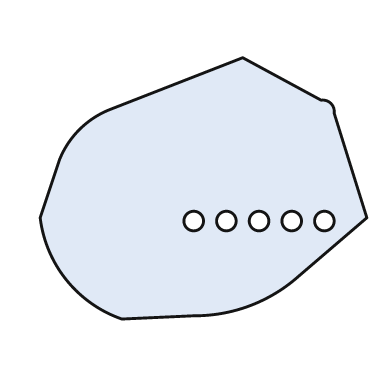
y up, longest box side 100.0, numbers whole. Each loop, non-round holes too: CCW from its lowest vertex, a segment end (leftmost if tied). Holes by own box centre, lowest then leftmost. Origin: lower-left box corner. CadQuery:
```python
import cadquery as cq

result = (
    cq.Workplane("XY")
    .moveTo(25.0, 0.0)
    .lineTo(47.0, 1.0)
    .threePointArc((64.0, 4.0), (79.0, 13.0))
    .lineTo(100.0, 31.0)
    .lineTo(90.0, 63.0)
    .threePointArc((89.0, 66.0), (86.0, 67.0))
    .lineTo(62.0, 80.0)
    .lineTo(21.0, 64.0)
    .threePointArc((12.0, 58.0), (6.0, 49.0))
    .lineTo(0.0, 31.0)
    .threePointArc((8.0, 12.0), (25.0, 0.0))
    .close()
    .moveTo(47.0, 30.0)
    .circle(3.0)
    .moveTo(57.0, 30.0)
    .circle(3.0)
    .moveTo(67.0, 30.0)
    .circle(3.0)
    .moveTo(77.0, 30.0)
    .circle(3.0)
    .moveTo(87.0, 30.0)
    .circle(3.0)
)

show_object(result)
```